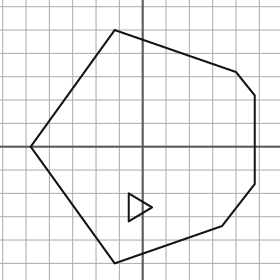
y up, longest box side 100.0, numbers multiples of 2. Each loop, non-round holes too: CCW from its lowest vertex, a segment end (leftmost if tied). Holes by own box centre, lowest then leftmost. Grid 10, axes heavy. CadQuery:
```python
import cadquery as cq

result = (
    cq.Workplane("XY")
    .moveTo(-12.0, -50.0)
    .lineTo(34.0, -34.0)
    .lineTo(48.0, -16.0)
    .lineTo(48.0, 22.0)
    .lineTo(40.0, 32.0)
    .lineTo(-12.0, 50.0)
    .lineTo(-48.0, 0.0)
    .close()
    .moveTo(-6.0, -32.0)
    .lineTo(4.0, -26.0)
    .lineTo(-6.0, -20.0)
    .close()
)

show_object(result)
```